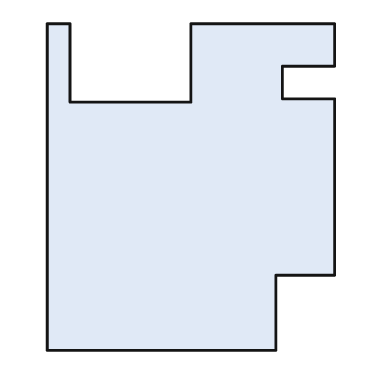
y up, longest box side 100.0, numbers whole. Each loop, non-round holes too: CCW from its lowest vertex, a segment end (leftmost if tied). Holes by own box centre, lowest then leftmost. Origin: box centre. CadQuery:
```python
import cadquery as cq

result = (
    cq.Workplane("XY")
    .moveTo(-44.0, -50.0)
    .lineTo(26.0, -50.0)
    .lineTo(26.0, -27.0)
    .lineTo(44.0, -27.0)
    .lineTo(44.0, 27.0)
    .lineTo(28.0, 27.0)
    .lineTo(28.0, 37.0)
    .lineTo(44.0, 37.0)
    .lineTo(44.0, 50.0)
    .lineTo(0.0, 50.0)
    .lineTo(0.0, 26.0)
    .lineTo(-37.0, 26.0)
    .lineTo(-37.0, 50.0)
    .lineTo(-44.0, 50.0)
    .close()
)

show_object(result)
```